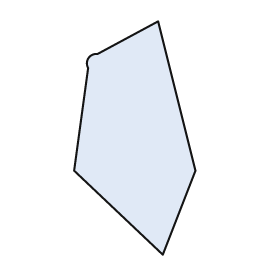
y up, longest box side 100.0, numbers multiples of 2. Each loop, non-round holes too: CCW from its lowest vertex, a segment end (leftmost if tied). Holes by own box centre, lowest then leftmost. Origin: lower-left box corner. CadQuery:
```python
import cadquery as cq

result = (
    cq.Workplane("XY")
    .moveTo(38.0, 0.0)
    .lineTo(52.0, 36.0)
    .lineTo(36.0, 100.0)
    .lineTo(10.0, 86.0)
    .threePointArc((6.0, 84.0), (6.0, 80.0))
    .lineTo(0.0, 36.0)
    .close()
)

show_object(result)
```